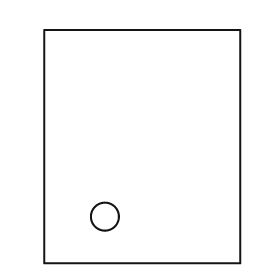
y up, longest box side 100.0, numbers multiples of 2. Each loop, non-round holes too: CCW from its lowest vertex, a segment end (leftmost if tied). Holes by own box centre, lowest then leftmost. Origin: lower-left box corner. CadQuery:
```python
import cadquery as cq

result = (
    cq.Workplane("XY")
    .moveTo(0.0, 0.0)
    .lineTo(84.0, 0.0)
    .lineTo(84.0, 100.0)
    .lineTo(0.0, 100.0)
    .close()
    .moveTo(26.0, 20.0)
    .circle(6.0)
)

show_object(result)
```